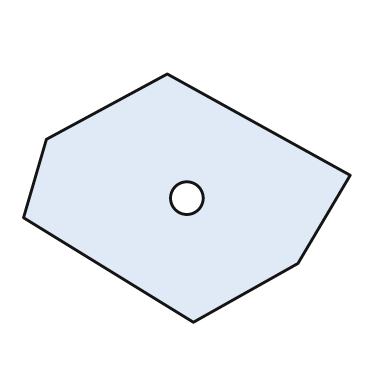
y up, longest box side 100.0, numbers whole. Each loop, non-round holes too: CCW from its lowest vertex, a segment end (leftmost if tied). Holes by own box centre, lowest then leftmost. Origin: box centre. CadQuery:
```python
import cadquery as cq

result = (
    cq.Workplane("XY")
    .moveTo(2.0, -38.0)
    .lineTo(34.0, -20.0)
    .lineTo(50.0, 7.0)
    .lineTo(-6.0, 38.0)
    .lineTo(-43.0, 18.0)
    .lineTo(-50.0, -6.0)
    .close()
    .moveTo(0.0, 0.0)
    .circle(5.0)
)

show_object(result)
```